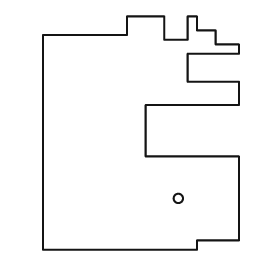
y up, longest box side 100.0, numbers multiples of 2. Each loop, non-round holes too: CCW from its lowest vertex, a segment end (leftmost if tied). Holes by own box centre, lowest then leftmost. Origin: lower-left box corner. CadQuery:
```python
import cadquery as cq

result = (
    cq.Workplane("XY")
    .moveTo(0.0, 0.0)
    .lineTo(66.0, 0.0)
    .lineTo(66.0, 4.0)
    .lineTo(84.0, 4.0)
    .lineTo(84.0, 40.0)
    .lineTo(44.0, 40.0)
    .lineTo(44.0, 62.0)
    .lineTo(84.0, 62.0)
    .lineTo(84.0, 72.0)
    .lineTo(62.0, 72.0)
    .lineTo(62.0, 84.0)
    .lineTo(84.0, 84.0)
    .lineTo(84.0, 88.0)
    .lineTo(74.0, 88.0)
    .lineTo(74.0, 94.0)
    .lineTo(66.0, 94.0)
    .lineTo(66.0, 100.0)
    .lineTo(62.0, 100.0)
    .lineTo(62.0, 90.0)
    .lineTo(52.0, 90.0)
    .lineTo(52.0, 100.0)
    .lineTo(36.0, 100.0)
    .lineTo(36.0, 92.0)
    .lineTo(0.0, 92.0)
    .close()
    .moveTo(58.0, 22.0)
    .circle(2.0)
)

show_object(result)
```